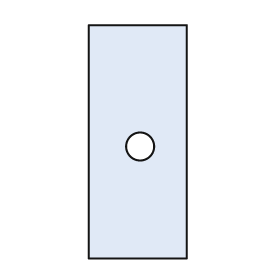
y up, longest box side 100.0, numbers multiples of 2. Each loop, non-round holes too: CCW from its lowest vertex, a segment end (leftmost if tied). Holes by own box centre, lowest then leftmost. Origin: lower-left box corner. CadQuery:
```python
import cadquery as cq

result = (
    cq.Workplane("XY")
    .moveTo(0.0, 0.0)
    .lineTo(42.0, 0.0)
    .lineTo(42.0, 100.0)
    .lineTo(0.0, 100.0)
    .close()
    .moveTo(22.0, 48.0)
    .circle(6.0)
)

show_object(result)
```